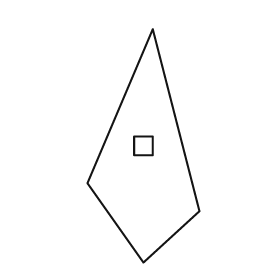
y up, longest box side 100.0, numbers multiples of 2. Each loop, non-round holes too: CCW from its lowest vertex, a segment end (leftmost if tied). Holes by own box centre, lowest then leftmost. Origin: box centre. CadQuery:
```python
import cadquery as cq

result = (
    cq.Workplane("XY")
    .moveTo(0.0, -50.0)
    .lineTo(24.0, -28.0)
    .lineTo(4.0, 50.0)
    .lineTo(-24.0, -16.0)
    .close()
    .moveTo(-4.0, -4.0)
    .lineTo(4.0, -4.0)
    .lineTo(4.0, 4.0)
    .lineTo(-4.0, 4.0)
    .close()
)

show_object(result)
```